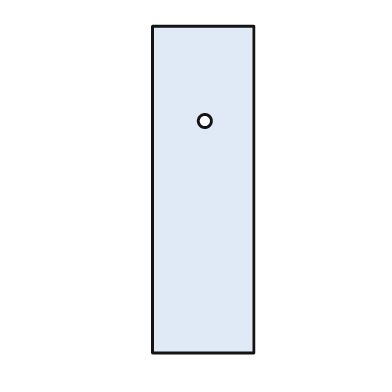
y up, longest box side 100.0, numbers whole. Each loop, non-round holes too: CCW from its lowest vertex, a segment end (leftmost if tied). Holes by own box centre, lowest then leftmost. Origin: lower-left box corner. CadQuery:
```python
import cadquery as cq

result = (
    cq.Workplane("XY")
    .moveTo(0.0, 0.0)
    .lineTo(31.0, 0.0)
    .lineTo(31.0, 100.0)
    .lineTo(0.0, 100.0)
    .close()
    .moveTo(16.0, 71.0)
    .circle(2.0)
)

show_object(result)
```